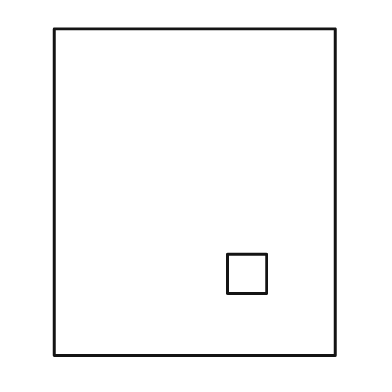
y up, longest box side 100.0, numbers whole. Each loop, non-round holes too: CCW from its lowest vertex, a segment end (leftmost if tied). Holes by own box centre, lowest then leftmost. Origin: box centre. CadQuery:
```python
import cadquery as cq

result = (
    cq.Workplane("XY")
    .moveTo(-43.0, -50.0)
    .lineTo(43.0, -50.0)
    .lineTo(43.0, 50.0)
    .lineTo(-43.0, 50.0)
    .close()
    .moveTo(10.0, -31.0)
    .lineTo(22.0, -31.0)
    .lineTo(22.0, -19.0)
    .lineTo(10.0, -19.0)
    .close()
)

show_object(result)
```